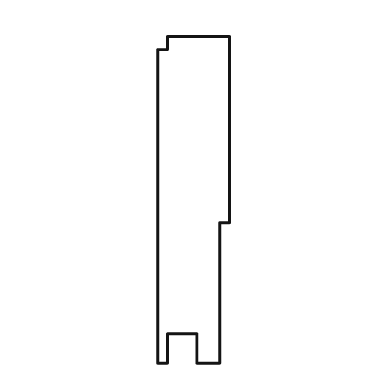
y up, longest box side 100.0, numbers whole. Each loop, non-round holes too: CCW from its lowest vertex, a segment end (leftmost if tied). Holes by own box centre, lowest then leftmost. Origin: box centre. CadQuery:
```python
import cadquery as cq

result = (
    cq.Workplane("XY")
    .moveTo(-11.0, -50.0)
    .lineTo(-8.0, -50.0)
    .lineTo(-8.0, -41.0)
    .lineTo(1.0, -41.0)
    .lineTo(1.0, -50.0)
    .lineTo(8.0, -50.0)
    .lineTo(8.0, -7.0)
    .lineTo(11.0, -7.0)
    .lineTo(11.0, 50.0)
    .lineTo(-8.0, 50.0)
    .lineTo(-8.0, 46.0)
    .lineTo(-11.0, 46.0)
    .close()
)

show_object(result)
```